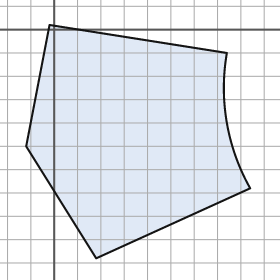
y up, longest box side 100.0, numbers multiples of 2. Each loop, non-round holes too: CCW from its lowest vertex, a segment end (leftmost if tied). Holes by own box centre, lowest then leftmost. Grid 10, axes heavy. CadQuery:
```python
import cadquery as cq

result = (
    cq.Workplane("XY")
    .moveTo(18.0, -98.0)
    .lineTo(84.0, -68.0)
    .threePointArc((74.0, -40.0), (74.0, -10.0))
    .lineTo(-2.0, 2.0)
    .lineTo(-12.0, -50.0)
    .close()
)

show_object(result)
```